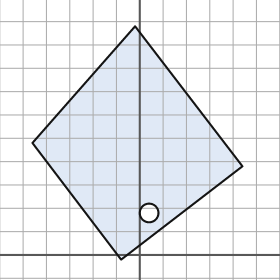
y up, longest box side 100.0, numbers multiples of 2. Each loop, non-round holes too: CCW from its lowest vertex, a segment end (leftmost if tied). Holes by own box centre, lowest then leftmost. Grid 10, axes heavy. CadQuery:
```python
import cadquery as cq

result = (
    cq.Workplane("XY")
    .moveTo(-8.0, -2.0)
    .lineTo(44.0, 38.0)
    .lineTo(-2.0, 98.0)
    .lineTo(-46.0, 48.0)
    .close()
    .moveTo(4.0, 18.0)
    .circle(4.0)
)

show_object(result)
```